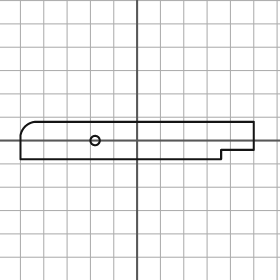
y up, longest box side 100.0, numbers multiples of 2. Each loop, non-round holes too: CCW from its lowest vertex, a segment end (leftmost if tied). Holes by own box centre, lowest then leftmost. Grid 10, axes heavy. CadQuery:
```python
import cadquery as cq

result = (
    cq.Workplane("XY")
    .moveTo(-50.0, -8.0)
    .lineTo(36.0, -8.0)
    .lineTo(36.0, -4.0)
    .lineTo(50.0, -4.0)
    .lineTo(50.0, 8.0)
    .lineTo(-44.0, 8.0)
    .threePointArc((-48.0, 6.0), (-50.0, 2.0))
    .close()
    .moveTo(-18.0, 0.0)
    .circle(2.0)
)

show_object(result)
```